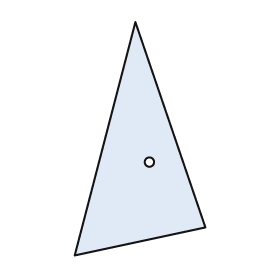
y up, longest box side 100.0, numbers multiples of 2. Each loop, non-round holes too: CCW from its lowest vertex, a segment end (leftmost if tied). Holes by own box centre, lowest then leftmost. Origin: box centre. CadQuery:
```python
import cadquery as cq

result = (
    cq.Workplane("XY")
    .moveTo(-28.0, -50.0)
    .lineTo(28.0, -38.0)
    .lineTo(-2.0, 50.0)
    .close()
    .moveTo(4.0, -10.0)
    .circle(2.0)
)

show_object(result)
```